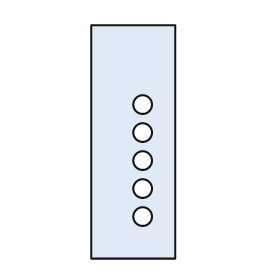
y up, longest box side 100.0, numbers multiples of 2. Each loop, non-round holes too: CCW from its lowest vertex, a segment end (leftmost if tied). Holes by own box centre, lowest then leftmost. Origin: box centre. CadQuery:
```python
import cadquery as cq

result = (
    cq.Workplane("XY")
    .moveTo(-18.0, -50.0)
    .lineTo(18.0, -50.0)
    .lineTo(18.0, 50.0)
    .lineTo(-18.0, 50.0)
    .close()
    .moveTo(4.0, -32.0)
    .circle(4.0)
    .moveTo(4.0, -20.0)
    .circle(4.0)
    .moveTo(4.0, -8.0)
    .circle(4.0)
    .moveTo(4.0, 4.0)
    .circle(4.0)
    .moveTo(4.0, 16.0)
    .circle(4.0)
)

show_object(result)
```